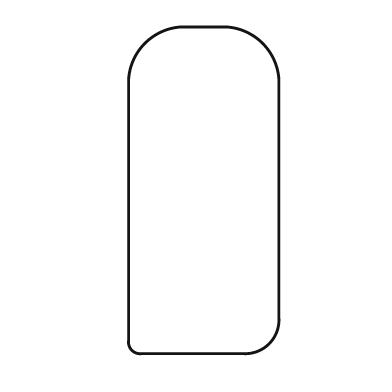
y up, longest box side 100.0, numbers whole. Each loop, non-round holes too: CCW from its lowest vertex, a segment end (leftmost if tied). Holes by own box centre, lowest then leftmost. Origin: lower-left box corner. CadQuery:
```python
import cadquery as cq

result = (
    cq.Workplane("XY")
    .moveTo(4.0, 0.0)
    .lineTo(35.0, 0.0)
    .threePointArc((43.0, 3.0), (46.0, 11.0))
    .lineTo(46.0, 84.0)
    .threePointArc((41.0, 95.0), (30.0, 100.0))
    .lineTo(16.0, 100.0)
    .threePointArc((5.0, 95.0), (0.0, 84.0))
    .lineTo(0.0, 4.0)
    .threePointArc((1.0, 1.0), (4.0, 0.0))
    .close()
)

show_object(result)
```